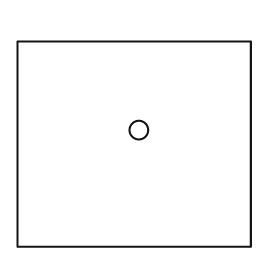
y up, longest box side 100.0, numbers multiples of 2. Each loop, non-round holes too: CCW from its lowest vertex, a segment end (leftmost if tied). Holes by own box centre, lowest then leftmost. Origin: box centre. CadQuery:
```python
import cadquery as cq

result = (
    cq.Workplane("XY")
    .moveTo(-50.0, -44.0)
    .lineTo(50.0, -44.0)
    .lineTo(50.0, 44.0)
    .lineTo(-50.0, 44.0)
    .close()
    .moveTo(2.0, 6.0)
    .circle(4.0)
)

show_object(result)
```